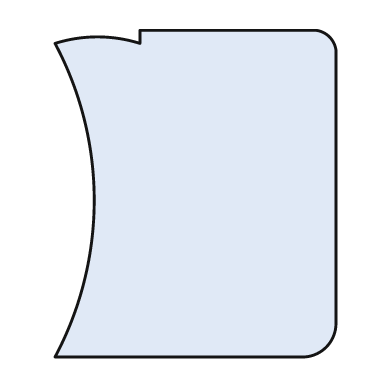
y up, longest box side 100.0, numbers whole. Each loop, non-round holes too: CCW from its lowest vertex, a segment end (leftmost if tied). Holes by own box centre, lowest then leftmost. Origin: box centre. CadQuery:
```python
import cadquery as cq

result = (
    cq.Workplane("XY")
    .moveTo(-43.0, -50.0)
    .lineTo(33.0, -50.0)
    .threePointArc((40.0, -47.0), (43.0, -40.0))
    .lineTo(43.0, 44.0)
    .threePointArc((41.0, 48.0), (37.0, 50.0))
    .lineTo(-17.0, 50.0)
    .lineTo(-17.0, 46.0)
    .threePointArc((-30.0, 48.0), (-43.0, 46.0))
    .threePointArc((-31.0, -2.0), (-43.0, -50.0))
    .close()
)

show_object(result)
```